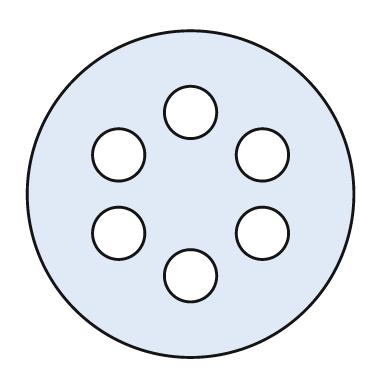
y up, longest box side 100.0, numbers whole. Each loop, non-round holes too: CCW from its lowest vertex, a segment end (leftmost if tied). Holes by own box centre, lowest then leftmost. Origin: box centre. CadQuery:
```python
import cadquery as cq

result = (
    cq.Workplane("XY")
    .moveTo(0.0, 0.0)
    .circle(50.0)
    .moveTo(0.0, -25.0)
    .circle(8.0)
    .moveTo(-22.0, -12.0)
    .circle(8.0)
    .moveTo(22.0, -12.0)
    .circle(8.0)
    .moveTo(-22.0, 12.0)
    .circle(8.0)
    .moveTo(22.0, 12.0)
    .circle(8.0)
    .moveTo(0.0, 25.0)
    .circle(8.0)
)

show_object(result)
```